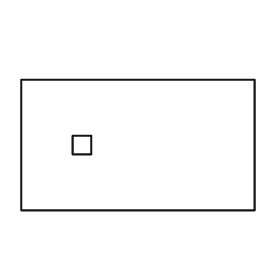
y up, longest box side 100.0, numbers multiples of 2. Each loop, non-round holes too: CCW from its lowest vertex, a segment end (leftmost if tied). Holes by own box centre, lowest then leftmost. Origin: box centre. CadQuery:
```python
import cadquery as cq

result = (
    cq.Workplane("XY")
    .moveTo(-50.0, -28.0)
    .lineTo(50.0, -28.0)
    .lineTo(50.0, 28.0)
    .lineTo(-50.0, 28.0)
    .close()
    .moveTo(-28.0, -4.0)
    .lineTo(-20.0, -4.0)
    .lineTo(-20.0, 4.0)
    .lineTo(-28.0, 4.0)
    .close()
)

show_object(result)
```